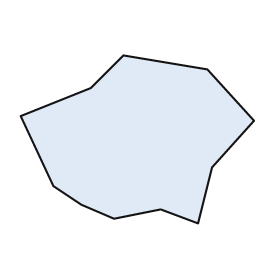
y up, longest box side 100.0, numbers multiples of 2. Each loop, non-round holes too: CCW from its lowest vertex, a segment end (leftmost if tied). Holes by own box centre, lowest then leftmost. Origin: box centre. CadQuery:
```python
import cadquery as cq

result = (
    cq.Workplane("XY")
    .moveTo(26.0, -36.0)
    .lineTo(32.0, -12.0)
    .lineTo(50.0, 8.0)
    .lineTo(30.0, 30.0)
    .lineTo(-6.0, 36.0)
    .lineTo(-20.0, 22.0)
    .lineTo(-50.0, 10.0)
    .lineTo(-36.0, -20.0)
    .lineTo(-24.0, -28.0)
    .lineTo(-10.0, -34.0)
    .lineTo(10.0, -30.0)
    .close()
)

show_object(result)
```